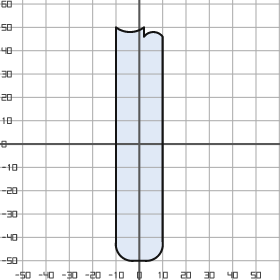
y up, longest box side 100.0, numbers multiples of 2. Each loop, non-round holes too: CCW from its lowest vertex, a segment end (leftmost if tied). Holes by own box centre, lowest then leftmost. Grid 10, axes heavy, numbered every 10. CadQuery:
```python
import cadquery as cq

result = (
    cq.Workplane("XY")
    .moveTo(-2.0, -50.0)
    .lineTo(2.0, -50.0)
    .threePointArc((8.0, -48.0), (10.0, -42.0))
    .lineTo(10.0, 46.0)
    .threePointArc((6.0, 48.0), (2.0, 46.0))
    .lineTo(2.0, 50.0)
    .threePointArc((-4.0, 48.0), (-10.0, 50.0))
    .lineTo(-10.0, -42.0)
    .threePointArc((-8.0, -48.0), (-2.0, -50.0))
    .close()
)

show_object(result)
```